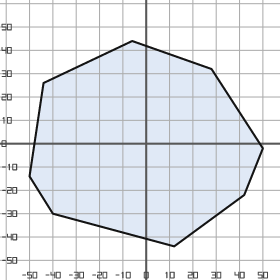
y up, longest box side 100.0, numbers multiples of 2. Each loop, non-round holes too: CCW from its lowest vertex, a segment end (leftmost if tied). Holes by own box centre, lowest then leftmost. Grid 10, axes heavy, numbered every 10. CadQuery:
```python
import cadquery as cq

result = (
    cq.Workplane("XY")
    .moveTo(12.0, -44.0)
    .lineTo(42.0, -22.0)
    .lineTo(50.0, -2.0)
    .lineTo(28.0, 32.0)
    .lineTo(-6.0, 44.0)
    .lineTo(-44.0, 26.0)
    .lineTo(-50.0, -14.0)
    .lineTo(-40.0, -30.0)
    .close()
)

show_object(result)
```